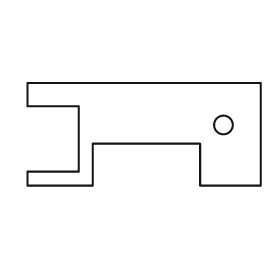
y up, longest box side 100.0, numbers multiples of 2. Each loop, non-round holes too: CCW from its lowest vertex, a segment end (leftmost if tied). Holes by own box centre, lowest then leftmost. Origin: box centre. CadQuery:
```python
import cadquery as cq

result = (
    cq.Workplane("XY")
    .moveTo(-50.0, -22.0)
    .lineTo(-22.0, -22.0)
    .lineTo(-22.0, -4.0)
    .lineTo(24.0, -4.0)
    .lineTo(24.0, -22.0)
    .lineTo(50.0, -22.0)
    .lineTo(50.0, 22.0)
    .lineTo(-50.0, 22.0)
    .lineTo(-50.0, 12.0)
    .lineTo(-28.0, 12.0)
    .lineTo(-28.0, -16.0)
    .lineTo(-50.0, -16.0)
    .close()
    .moveTo(34.0, 4.0)
    .circle(4.0)
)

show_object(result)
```